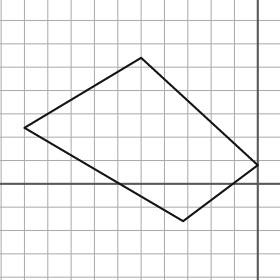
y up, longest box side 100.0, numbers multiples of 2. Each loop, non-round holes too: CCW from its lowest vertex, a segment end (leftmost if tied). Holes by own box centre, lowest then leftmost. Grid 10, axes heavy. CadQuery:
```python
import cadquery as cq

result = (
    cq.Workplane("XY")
    .moveTo(-32.0, -16.0)
    .lineTo(0.0, 8.0)
    .lineTo(-50.0, 54.0)
    .lineTo(-100.0, 24.0)
    .close()
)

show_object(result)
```